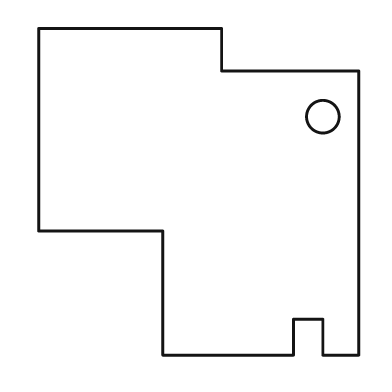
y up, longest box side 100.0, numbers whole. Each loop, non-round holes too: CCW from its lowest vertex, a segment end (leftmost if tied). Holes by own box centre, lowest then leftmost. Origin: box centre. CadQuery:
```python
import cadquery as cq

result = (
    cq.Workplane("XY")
    .moveTo(-11.0, -50.0)
    .lineTo(29.0, -50.0)
    .lineTo(29.0, -39.0)
    .lineTo(38.0, -39.0)
    .lineTo(38.0, -50.0)
    .lineTo(49.0, -50.0)
    .lineTo(49.0, 37.0)
    .lineTo(7.0, 37.0)
    .lineTo(7.0, 50.0)
    .lineTo(-49.0, 50.0)
    .lineTo(-49.0, -12.0)
    .lineTo(-11.0, -12.0)
    .close()
    .moveTo(38.0, 23.0)
    .circle(5.0)
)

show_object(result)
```